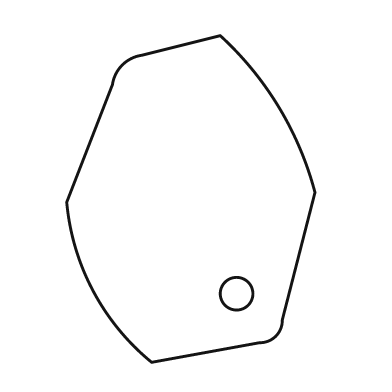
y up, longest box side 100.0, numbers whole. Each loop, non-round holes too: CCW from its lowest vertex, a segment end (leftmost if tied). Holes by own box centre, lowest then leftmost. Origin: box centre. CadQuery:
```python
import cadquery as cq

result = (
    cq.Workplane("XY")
    .moveTo(-12.0, -50.0)
    .lineTo(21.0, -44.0)
    .threePointArc((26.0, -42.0), (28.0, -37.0))
    .lineTo(38.0, 2.0)
    .threePointArc((27.0, 28.0), (9.0, 50.0))
    .lineTo(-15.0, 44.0)
    .threePointArc((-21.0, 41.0), (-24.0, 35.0))
    .lineTo(-38.0, -1.0)
    .threePointArc((-30.0, -28.0), (-12.0, -50.0))
    .close()
    .moveTo(14.0, -29.0)
    .circle(5.0)
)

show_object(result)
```